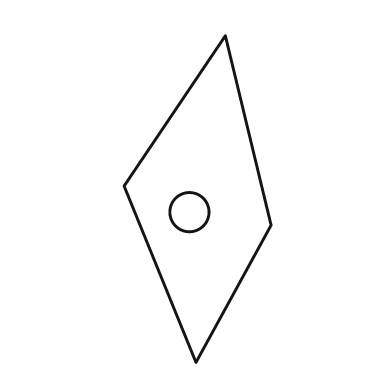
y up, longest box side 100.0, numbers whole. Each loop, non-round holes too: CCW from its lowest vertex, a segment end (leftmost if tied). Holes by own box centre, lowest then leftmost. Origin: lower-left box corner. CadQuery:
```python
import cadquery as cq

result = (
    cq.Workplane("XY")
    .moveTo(22.0, 0.0)
    .lineTo(45.0, 42.0)
    .lineTo(31.0, 100.0)
    .lineTo(0.0, 54.0)
    .close()
    .moveTo(20.0, 46.0)
    .circle(6.0)
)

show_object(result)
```